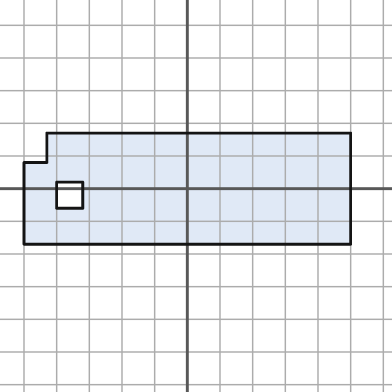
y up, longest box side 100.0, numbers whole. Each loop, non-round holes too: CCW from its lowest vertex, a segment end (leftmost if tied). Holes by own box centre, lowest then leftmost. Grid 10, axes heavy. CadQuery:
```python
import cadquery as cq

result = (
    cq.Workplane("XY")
    .moveTo(-50.0, -17.0)
    .lineTo(50.0, -17.0)
    .lineTo(50.0, 17.0)
    .lineTo(-43.0, 17.0)
    .lineTo(-43.0, 8.0)
    .lineTo(-50.0, 8.0)
    .close()
    .moveTo(-40.0, -6.0)
    .lineTo(-32.0, -6.0)
    .lineTo(-32.0, 2.0)
    .lineTo(-40.0, 2.0)
    .close()
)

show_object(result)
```